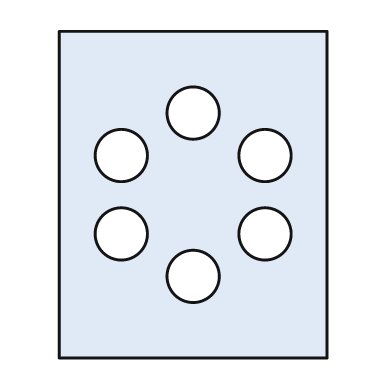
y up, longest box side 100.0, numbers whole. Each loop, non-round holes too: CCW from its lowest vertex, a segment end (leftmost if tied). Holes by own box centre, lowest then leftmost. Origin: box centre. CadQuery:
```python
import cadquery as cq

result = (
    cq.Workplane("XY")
    .moveTo(-41.0, -50.0)
    .lineTo(41.0, -50.0)
    .lineTo(41.0, 50.0)
    .lineTo(-41.0, 50.0)
    .close()
    .moveTo(0.0, -25.0)
    .circle(8.0)
    .moveTo(-22.0, -12.0)
    .circle(8.0)
    .moveTo(22.0, -12.0)
    .circle(8.0)
    .moveTo(-22.0, 12.0)
    .circle(8.0)
    .moveTo(22.0, 12.0)
    .circle(8.0)
    .moveTo(0.0, 25.0)
    .circle(8.0)
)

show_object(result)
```